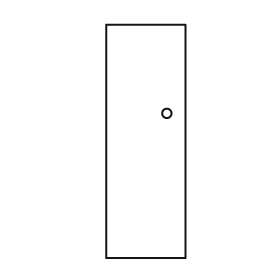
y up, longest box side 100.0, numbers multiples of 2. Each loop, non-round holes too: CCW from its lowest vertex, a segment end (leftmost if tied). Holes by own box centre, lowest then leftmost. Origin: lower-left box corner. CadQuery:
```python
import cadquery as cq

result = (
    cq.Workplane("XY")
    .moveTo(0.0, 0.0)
    .lineTo(34.0, 0.0)
    .lineTo(34.0, 100.0)
    .lineTo(0.0, 100.0)
    .close()
    .moveTo(26.0, 62.0)
    .circle(2.0)
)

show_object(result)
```